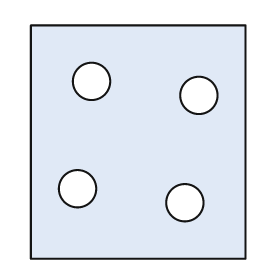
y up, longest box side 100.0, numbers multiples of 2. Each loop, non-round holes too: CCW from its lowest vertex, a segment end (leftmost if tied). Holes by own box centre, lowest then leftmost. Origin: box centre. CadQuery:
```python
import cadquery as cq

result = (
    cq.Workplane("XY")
    .moveTo(-46.0, -50.0)
    .lineTo(46.0, -50.0)
    .lineTo(46.0, 50.0)
    .lineTo(-46.0, 50.0)
    .close()
    .moveTo(20.0, -26.0)
    .circle(8.0)
    .moveTo(-26.0, -20.0)
    .circle(8.0)
    .moveTo(26.0, 20.0)
    .circle(8.0)
    .moveTo(-20.0, 26.0)
    .circle(8.0)
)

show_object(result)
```